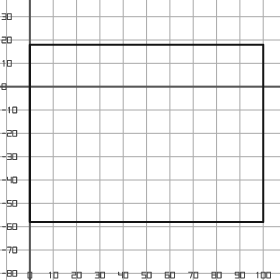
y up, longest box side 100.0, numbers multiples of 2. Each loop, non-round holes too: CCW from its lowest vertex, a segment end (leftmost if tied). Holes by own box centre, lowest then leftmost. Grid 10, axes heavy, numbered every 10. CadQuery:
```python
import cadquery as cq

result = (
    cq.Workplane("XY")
    .moveTo(0.0, -58.0)
    .lineTo(100.0, -58.0)
    .lineTo(100.0, 18.0)
    .lineTo(0.0, 18.0)
    .close()
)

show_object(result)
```